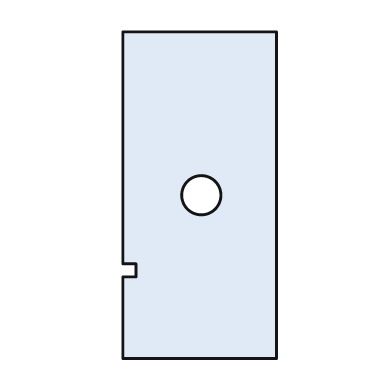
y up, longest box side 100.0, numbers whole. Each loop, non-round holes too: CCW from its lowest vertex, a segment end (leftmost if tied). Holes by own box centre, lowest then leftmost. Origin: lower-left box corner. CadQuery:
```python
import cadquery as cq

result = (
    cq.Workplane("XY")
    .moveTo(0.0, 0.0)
    .lineTo(47.0, 0.0)
    .lineTo(47.0, 100.0)
    .lineTo(0.0, 100.0)
    .lineTo(0.0, 29.0)
    .lineTo(4.0, 29.0)
    .lineTo(4.0, 25.0)
    .lineTo(0.0, 25.0)
    .close()
    .moveTo(24.0, 50.0)
    .circle(6.0)
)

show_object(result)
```